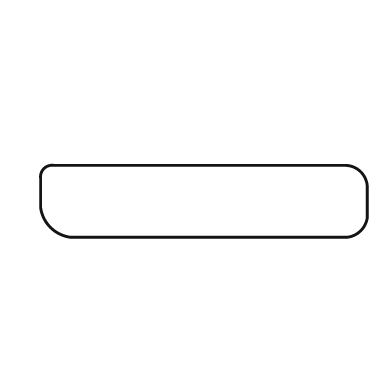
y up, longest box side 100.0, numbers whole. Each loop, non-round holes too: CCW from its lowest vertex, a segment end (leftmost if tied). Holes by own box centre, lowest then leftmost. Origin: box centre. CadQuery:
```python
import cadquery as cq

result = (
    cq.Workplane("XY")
    .moveTo(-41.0, -11.0)
    .lineTo(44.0, -11.0)
    .threePointArc((48.0, -9.0), (50.0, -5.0))
    .lineTo(50.0, 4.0)
    .threePointArc((48.0, 9.0), (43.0, 11.0))
    .lineTo(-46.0, 11.0)
    .threePointArc((-49.0, 10.0), (-50.0, 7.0))
    .lineTo(-50.0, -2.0)
    .threePointArc((-47.0, -8.0), (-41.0, -11.0))
    .close()
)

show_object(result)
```